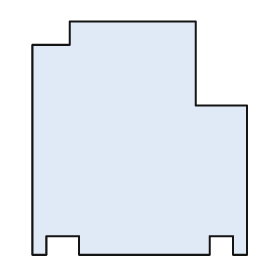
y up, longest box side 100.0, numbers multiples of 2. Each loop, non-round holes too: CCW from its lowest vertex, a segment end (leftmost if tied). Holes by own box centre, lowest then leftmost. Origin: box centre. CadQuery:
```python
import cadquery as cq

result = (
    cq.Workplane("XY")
    .moveTo(-46.0, -50.0)
    .lineTo(-40.0, -50.0)
    .lineTo(-40.0, -42.0)
    .lineTo(-26.0, -42.0)
    .lineTo(-26.0, -50.0)
    .lineTo(30.0, -50.0)
    .lineTo(30.0, -42.0)
    .lineTo(40.0, -42.0)
    .lineTo(40.0, -50.0)
    .lineTo(46.0, -50.0)
    .lineTo(46.0, 14.0)
    .lineTo(24.0, 14.0)
    .lineTo(24.0, 50.0)
    .lineTo(-30.0, 50.0)
    .lineTo(-30.0, 40.0)
    .lineTo(-46.0, 40.0)
    .close()
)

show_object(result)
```